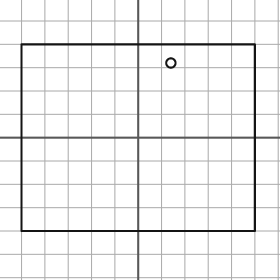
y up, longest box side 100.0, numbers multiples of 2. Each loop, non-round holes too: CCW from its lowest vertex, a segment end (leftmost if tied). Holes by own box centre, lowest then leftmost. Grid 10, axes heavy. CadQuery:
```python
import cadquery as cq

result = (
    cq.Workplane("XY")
    .moveTo(-50.0, -40.0)
    .lineTo(50.0, -40.0)
    .lineTo(50.0, 40.0)
    .lineTo(-50.0, 40.0)
    .close()
    .moveTo(14.0, 32.0)
    .circle(2.0)
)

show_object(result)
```